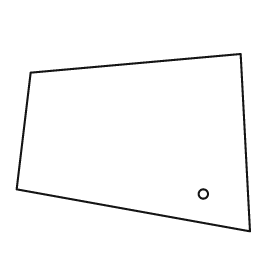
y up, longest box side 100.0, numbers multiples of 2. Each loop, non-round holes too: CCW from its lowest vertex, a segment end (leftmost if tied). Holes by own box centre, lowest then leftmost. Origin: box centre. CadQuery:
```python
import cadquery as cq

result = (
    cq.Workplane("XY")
    .moveTo(50.0, -38.0)
    .lineTo(46.0, 38.0)
    .lineTo(-44.0, 30.0)
    .lineTo(-50.0, -20.0)
    .close()
    .moveTo(30.0, -22.0)
    .circle(2.0)
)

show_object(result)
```